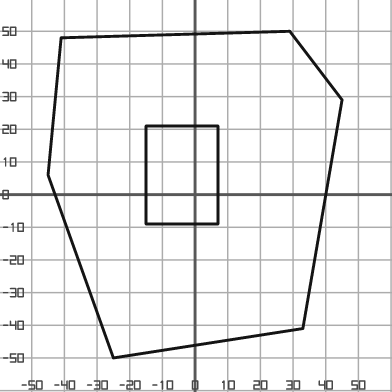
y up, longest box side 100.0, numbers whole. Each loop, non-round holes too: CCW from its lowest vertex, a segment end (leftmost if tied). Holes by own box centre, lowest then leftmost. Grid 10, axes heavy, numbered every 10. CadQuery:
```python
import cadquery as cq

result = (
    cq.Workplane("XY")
    .moveTo(-25.0, -50.0)
    .lineTo(33.0, -41.0)
    .lineTo(45.0, 29.0)
    .lineTo(29.0, 50.0)
    .lineTo(-41.0, 48.0)
    .lineTo(-45.0, 6.0)
    .close()
    .moveTo(-15.0, -9.0)
    .lineTo(7.0, -9.0)
    .lineTo(7.0, 21.0)
    .lineTo(-15.0, 21.0)
    .close()
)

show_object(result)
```